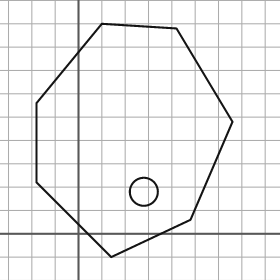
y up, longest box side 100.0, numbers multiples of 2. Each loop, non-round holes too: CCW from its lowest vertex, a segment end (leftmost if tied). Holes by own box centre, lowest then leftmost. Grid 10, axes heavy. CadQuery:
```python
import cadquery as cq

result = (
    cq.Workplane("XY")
    .moveTo(14.0, -10.0)
    .lineTo(48.0, 6.0)
    .lineTo(66.0, 48.0)
    .lineTo(42.0, 88.0)
    .lineTo(10.0, 90.0)
    .lineTo(-18.0, 56.0)
    .lineTo(-18.0, 22.0)
    .close()
    .moveTo(28.0, 18.0)
    .circle(6.0)
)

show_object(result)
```